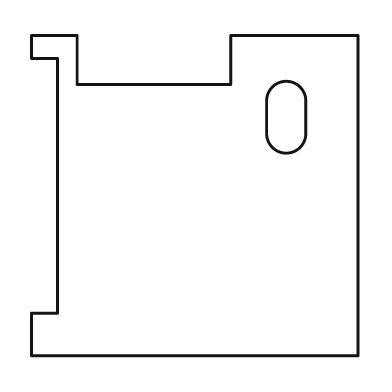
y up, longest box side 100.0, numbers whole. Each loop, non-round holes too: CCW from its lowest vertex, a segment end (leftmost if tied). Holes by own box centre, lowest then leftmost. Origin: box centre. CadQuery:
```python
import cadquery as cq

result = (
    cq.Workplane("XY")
    .moveTo(-50.0, -49.0)
    .lineTo(50.0, -49.0)
    .lineTo(50.0, 49.0)
    .lineTo(11.0, 49.0)
    .lineTo(11.0, 34.0)
    .lineTo(-36.0, 34.0)
    .lineTo(-36.0, 49.0)
    .lineTo(-50.0, 49.0)
    .lineTo(-50.0, 42.0)
    .lineTo(-42.0, 42.0)
    .lineTo(-42.0, -36.0)
    .lineTo(-50.0, -36.0)
    .close()
    .moveTo(22.0, 19.0)
    .threePointArc((28.0, 13.0), (34.0, 19.0))
    .lineTo(34.0, 29.0)
    .threePointArc((28.0, 35.0), (22.0, 29.0))
    .close()
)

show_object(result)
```